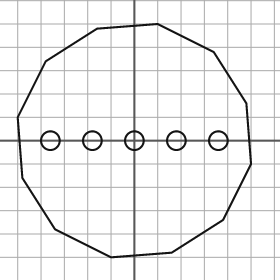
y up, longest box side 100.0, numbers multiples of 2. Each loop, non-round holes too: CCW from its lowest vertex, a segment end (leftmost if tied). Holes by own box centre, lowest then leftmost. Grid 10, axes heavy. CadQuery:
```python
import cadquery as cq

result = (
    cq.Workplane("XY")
    .moveTo(-10.0, -50.0)
    .lineTo(16.0, -48.0)
    .lineTo(38.0, -34.0)
    .lineTo(50.0, -10.0)
    .lineTo(48.0, 16.0)
    .lineTo(34.0, 38.0)
    .lineTo(10.0, 50.0)
    .lineTo(-16.0, 48.0)
    .lineTo(-38.0, 34.0)
    .lineTo(-50.0, 10.0)
    .lineTo(-48.0, -16.0)
    .lineTo(-34.0, -38.0)
    .close()
    .moveTo(-36.0, 0.0)
    .circle(4.0)
    .moveTo(-18.0, 0.0)
    .circle(4.0)
    .moveTo(0.0, 0.0)
    .circle(4.0)
    .moveTo(18.0, 0.0)
    .circle(4.0)
    .moveTo(36.0, 0.0)
    .circle(4.0)
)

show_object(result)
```